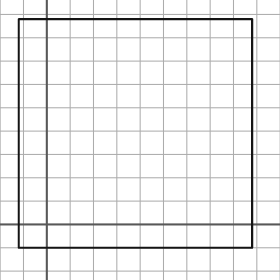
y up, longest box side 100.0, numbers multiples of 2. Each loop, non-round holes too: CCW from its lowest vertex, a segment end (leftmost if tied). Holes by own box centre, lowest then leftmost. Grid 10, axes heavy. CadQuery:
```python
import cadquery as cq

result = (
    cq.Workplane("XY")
    .moveTo(-12.0, -10.0)
    .lineTo(88.0, -10.0)
    .lineTo(88.0, 88.0)
    .lineTo(-12.0, 88.0)
    .close()
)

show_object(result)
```